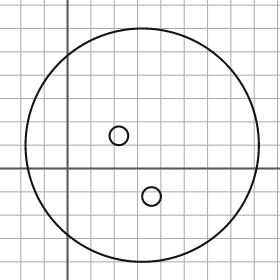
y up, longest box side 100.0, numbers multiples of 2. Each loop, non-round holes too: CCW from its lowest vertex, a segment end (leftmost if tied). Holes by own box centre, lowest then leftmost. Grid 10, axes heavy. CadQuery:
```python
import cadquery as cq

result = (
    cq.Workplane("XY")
    .moveTo(32.0, 10.0)
    .circle(50.0)
    .moveTo(36.0, -12.0)
    .circle(4.0)
    .moveTo(22.0, 14.0)
    .circle(4.0)
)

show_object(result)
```